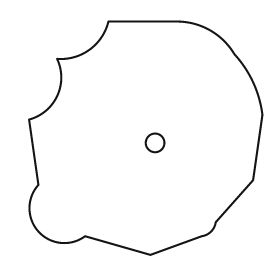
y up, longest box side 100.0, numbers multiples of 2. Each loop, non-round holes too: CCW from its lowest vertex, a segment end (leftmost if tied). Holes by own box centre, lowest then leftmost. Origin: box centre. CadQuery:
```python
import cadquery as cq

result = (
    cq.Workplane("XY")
    .moveTo(2.0, -50.0)
    .lineTo(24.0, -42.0)
    .threePointArc((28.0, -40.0), (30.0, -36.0))
    .lineTo(46.0, -18.0)
    .lineTo(50.0, 10.0)
    .threePointArc((46.0, 24.0), (38.0, 36.0))
    .threePointArc((28.0, 46.0), (14.0, 50.0))
    .lineTo(-16.0, 50.0)
    .threePointArc((-24.0, 38.0), (-38.0, 34.0))
    .threePointArc((-38.0, 18.0), (-50.0, 8.0))
    .lineTo(-46.0, -20.0)
    .threePointArc((-46.0, -40.0), (-26.0, -42.0))
    .close()
    .moveTo(4.0, -2.0)
    .circle(4.0)
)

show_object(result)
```